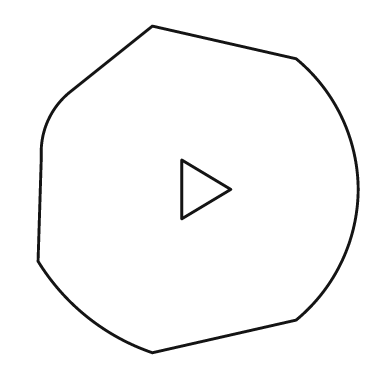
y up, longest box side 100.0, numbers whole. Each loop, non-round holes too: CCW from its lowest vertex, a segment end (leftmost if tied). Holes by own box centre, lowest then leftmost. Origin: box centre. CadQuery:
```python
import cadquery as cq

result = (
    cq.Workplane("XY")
    .moveTo(-14.0, -50.0)
    .lineTo(30.0, -40.0)
    .threePointArc((44.0, -22.0), (49.0, 0.0))
    .threePointArc((44.0, 22.0), (30.0, 40.0))
    .lineTo(-14.0, 50.0)
    .lineTo(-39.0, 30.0)
    .threePointArc((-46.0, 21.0), (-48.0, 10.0))
    .lineTo(-49.0, -22.0)
    .threePointArc((-34.0, -39.0), (-14.0, -50.0))
    .close()
    .moveTo(-5.0, -9.0)
    .lineTo(10.0, 0.0)
    .lineTo(-5.0, 9.0)
    .close()
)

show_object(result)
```